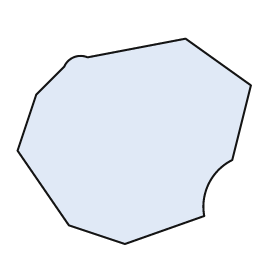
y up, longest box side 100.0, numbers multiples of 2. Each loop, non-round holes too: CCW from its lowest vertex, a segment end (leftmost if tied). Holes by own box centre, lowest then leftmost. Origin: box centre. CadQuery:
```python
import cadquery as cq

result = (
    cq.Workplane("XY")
    .moveTo(-4.0, -44.0)
    .lineTo(30.0, -32.0)
    .threePointArc((32.0, -18.0), (42.0, -8.0))
    .lineTo(50.0, 24.0)
    .lineTo(22.0, 44.0)
    .lineTo(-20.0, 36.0)
    .threePointArc((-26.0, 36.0), (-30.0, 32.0))
    .lineTo(-42.0, 20.0)
    .lineTo(-50.0, -4.0)
    .lineTo(-28.0, -36.0)
    .close()
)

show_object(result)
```